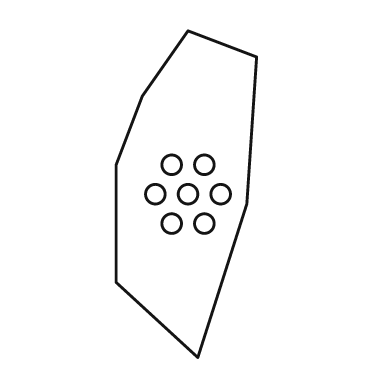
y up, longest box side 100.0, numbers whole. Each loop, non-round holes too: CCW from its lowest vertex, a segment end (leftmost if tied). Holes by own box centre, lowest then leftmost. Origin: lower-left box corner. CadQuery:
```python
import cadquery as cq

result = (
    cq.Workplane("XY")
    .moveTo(25.0, 0.0)
    .lineTo(40.0, 47.0)
    .lineTo(43.0, 92.0)
    .lineTo(22.0, 100.0)
    .lineTo(8.0, 80.0)
    .lineTo(0.0, 59.0)
    .lineTo(0.0, 23.0)
    .close()
    .moveTo(17.0, 41.0)
    .circle(3.0)
    .moveTo(27.0, 41.0)
    .circle(3.0)
    .moveTo(12.0, 50.0)
    .circle(3.0)
    .moveTo(22.0, 50.0)
    .circle(3.0)
    .moveTo(32.0, 50.0)
    .circle(3.0)
    .moveTo(17.0, 59.0)
    .circle(3.0)
    .moveTo(27.0, 59.0)
    .circle(3.0)
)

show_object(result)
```